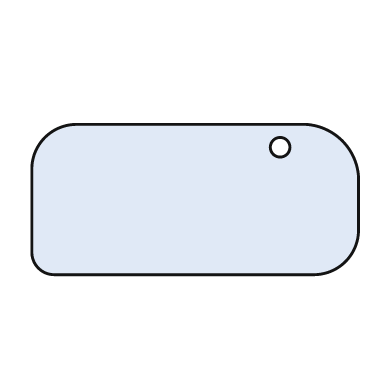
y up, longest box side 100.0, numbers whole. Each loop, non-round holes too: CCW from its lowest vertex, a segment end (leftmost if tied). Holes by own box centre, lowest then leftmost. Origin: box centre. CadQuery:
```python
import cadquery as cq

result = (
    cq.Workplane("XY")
    .moveTo(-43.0, -23.0)
    .lineTo(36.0, -23.0)
    .threePointArc((46.0, -19.0), (50.0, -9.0))
    .lineTo(50.0, 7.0)
    .threePointArc((45.0, 18.0), (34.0, 23.0))
    .lineTo(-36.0, 23.0)
    .threePointArc((-46.0, 19.0), (-50.0, 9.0))
    .lineTo(-50.0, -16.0)
    .threePointArc((-48.0, -21.0), (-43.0, -23.0))
    .close()
    .moveTo(26.0, 16.0)
    .circle(3.0)
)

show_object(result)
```